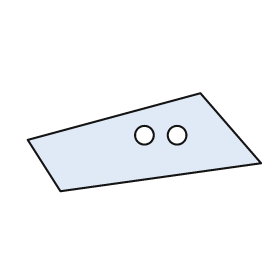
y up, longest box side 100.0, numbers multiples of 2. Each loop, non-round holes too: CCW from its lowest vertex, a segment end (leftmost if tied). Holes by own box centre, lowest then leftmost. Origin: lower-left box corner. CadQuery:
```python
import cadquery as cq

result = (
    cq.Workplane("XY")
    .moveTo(14.0, 0.0)
    .lineTo(100.0, 12.0)
    .lineTo(74.0, 42.0)
    .lineTo(0.0, 22.0)
    .close()
    .moveTo(50.0, 24.0)
    .circle(4.0)
    .moveTo(64.0, 24.0)
    .circle(4.0)
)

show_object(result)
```